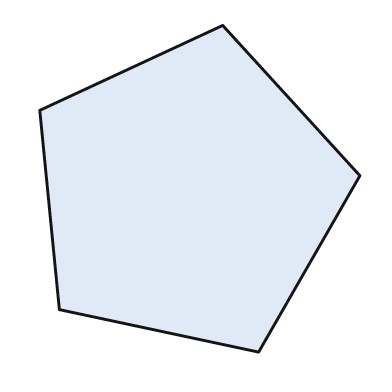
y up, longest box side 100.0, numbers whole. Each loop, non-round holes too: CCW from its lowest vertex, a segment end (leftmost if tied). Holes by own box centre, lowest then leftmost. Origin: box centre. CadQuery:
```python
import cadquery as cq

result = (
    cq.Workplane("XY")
    .moveTo(18.0, -50.0)
    .lineTo(49.0, 4.0)
    .lineTo(7.0, 50.0)
    .lineTo(-49.0, 24.0)
    .lineTo(-43.0, -37.0)
    .close()
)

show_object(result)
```